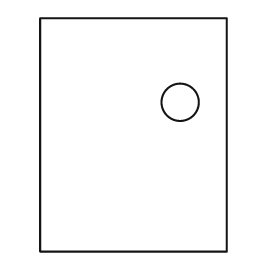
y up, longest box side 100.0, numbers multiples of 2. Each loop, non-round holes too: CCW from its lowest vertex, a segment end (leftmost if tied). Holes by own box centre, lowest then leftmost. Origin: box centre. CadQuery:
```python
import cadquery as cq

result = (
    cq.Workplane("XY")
    .moveTo(-40.0, -50.0)
    .lineTo(40.0, -50.0)
    .lineTo(40.0, 50.0)
    .lineTo(-40.0, 50.0)
    .close()
    .moveTo(20.0, 14.0)
    .circle(8.0)
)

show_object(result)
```